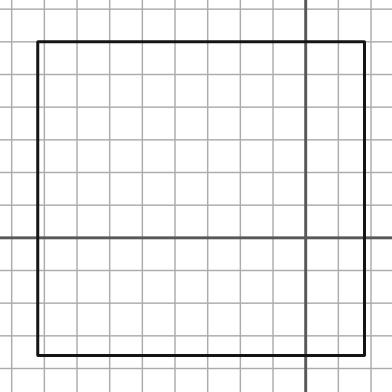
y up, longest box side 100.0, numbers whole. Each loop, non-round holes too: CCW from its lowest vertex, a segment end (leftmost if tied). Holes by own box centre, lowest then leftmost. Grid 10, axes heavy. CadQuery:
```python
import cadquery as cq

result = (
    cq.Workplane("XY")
    .moveTo(-82.0, -36.0)
    .lineTo(18.0, -36.0)
    .lineTo(18.0, 60.0)
    .lineTo(-82.0, 60.0)
    .close()
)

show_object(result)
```